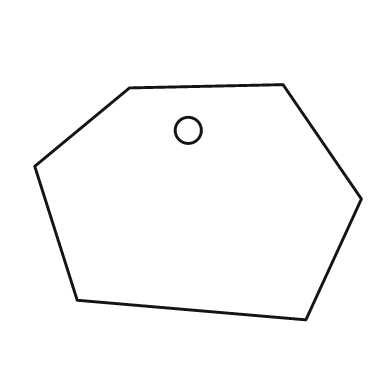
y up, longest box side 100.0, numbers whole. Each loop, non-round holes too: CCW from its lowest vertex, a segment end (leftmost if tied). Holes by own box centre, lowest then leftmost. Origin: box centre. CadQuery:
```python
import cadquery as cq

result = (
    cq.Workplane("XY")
    .moveTo(33.0, -36.0)
    .lineTo(50.0, 1.0)
    .lineTo(26.0, 36.0)
    .lineTo(-21.0, 35.0)
    .lineTo(-50.0, 11.0)
    .lineTo(-37.0, -30.0)
    .close()
    .moveTo(-3.0, 22.0)
    .circle(4.0)
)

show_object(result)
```